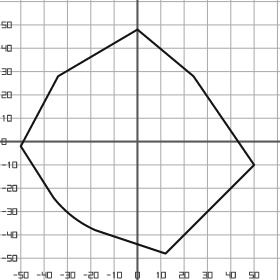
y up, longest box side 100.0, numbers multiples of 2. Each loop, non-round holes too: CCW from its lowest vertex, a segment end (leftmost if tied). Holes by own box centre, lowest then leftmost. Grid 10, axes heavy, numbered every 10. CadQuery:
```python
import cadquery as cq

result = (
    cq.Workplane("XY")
    .moveTo(12.0, -48.0)
    .lineTo(50.0, -10.0)
    .lineTo(24.0, 28.0)
    .lineTo(0.0, 48.0)
    .lineTo(-34.0, 28.0)
    .lineTo(-50.0, -2.0)
    .lineTo(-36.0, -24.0)
    .threePointArc((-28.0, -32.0), (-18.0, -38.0))
    .close()
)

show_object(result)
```